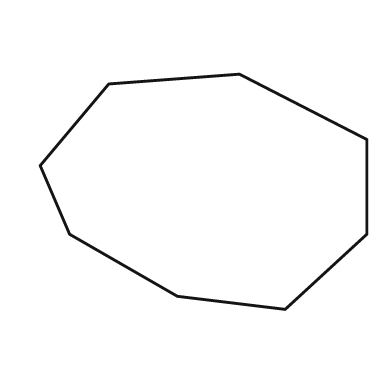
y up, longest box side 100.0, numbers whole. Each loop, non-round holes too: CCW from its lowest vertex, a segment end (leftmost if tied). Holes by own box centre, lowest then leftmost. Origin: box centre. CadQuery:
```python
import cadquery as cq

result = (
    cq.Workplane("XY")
    .moveTo(25.0, -36.0)
    .lineTo(50.0, -13.0)
    .lineTo(50.0, 16.0)
    .lineTo(11.0, 36.0)
    .lineTo(-29.0, 33.0)
    .lineTo(-50.0, 8.0)
    .lineTo(-41.0, -13.0)
    .lineTo(-8.0, -32.0)
    .close()
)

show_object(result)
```